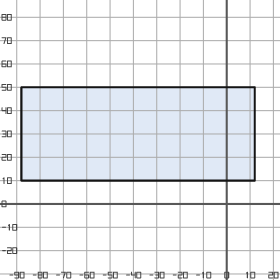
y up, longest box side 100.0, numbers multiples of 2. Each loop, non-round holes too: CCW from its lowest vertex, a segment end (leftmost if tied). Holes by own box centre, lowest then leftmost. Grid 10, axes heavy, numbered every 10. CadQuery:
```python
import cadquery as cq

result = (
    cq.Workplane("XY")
    .moveTo(-88.0, 10.0)
    .lineTo(12.0, 10.0)
    .lineTo(12.0, 50.0)
    .lineTo(-88.0, 50.0)
    .close()
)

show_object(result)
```